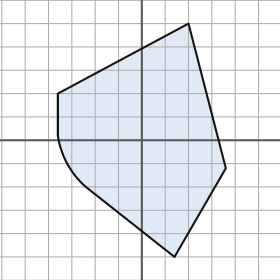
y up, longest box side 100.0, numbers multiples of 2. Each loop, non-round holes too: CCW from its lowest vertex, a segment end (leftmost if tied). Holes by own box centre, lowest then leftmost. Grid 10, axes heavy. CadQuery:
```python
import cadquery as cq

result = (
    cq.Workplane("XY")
    .moveTo(14.0, -50.0)
    .lineTo(36.0, -12.0)
    .lineTo(20.0, 50.0)
    .lineTo(-36.0, 20.0)
    .lineTo(-36.0, 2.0)
    .threePointArc((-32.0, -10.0), (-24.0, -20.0))
    .close()
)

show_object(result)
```